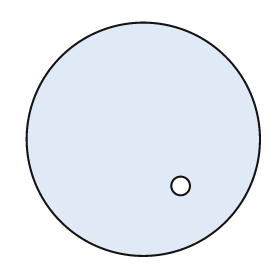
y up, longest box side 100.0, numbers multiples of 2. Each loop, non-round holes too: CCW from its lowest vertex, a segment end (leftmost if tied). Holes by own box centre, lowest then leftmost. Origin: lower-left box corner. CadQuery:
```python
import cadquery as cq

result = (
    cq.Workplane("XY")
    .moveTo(50.0, 50.0)
    .circle(50.0)
    .moveTo(66.0, 30.0)
    .circle(4.0)
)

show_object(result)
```